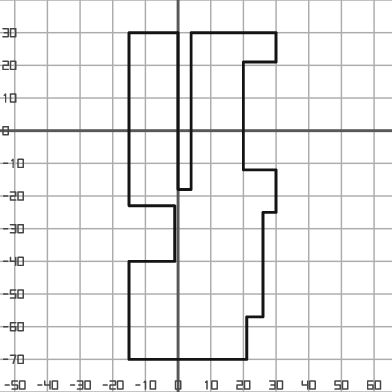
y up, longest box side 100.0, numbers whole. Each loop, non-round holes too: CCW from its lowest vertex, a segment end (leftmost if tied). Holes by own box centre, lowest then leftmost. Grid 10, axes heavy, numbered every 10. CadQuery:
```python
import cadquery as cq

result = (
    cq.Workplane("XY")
    .moveTo(-15.0, -70.0)
    .lineTo(21.0, -70.0)
    .lineTo(21.0, -57.0)
    .lineTo(26.0, -57.0)
    .lineTo(26.0, -25.0)
    .lineTo(30.0, -25.0)
    .lineTo(30.0, -12.0)
    .lineTo(20.0, -12.0)
    .lineTo(20.0, 21.0)
    .lineTo(30.0, 21.0)
    .lineTo(30.0, 30.0)
    .lineTo(4.0, 30.0)
    .lineTo(4.0, -18.0)
    .lineTo(0.0, -18.0)
    .lineTo(0.0, 30.0)
    .lineTo(-15.0, 30.0)
    .lineTo(-15.0, -23.0)
    .lineTo(-1.0, -23.0)
    .lineTo(-1.0, -40.0)
    .lineTo(-15.0, -40.0)
    .close()
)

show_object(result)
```